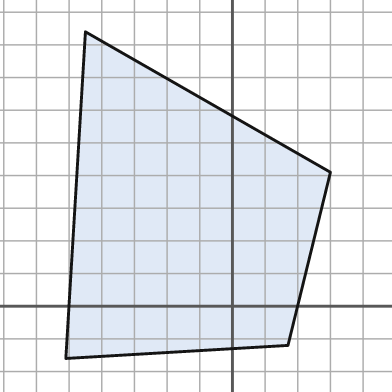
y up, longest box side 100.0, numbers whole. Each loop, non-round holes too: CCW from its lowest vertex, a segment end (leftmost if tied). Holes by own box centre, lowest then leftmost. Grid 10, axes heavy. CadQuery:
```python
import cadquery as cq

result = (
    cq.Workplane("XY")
    .moveTo(-51.0, -16.0)
    .lineTo(17.0, -12.0)
    .lineTo(30.0, 41.0)
    .lineTo(-45.0, 84.0)
    .close()
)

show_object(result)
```